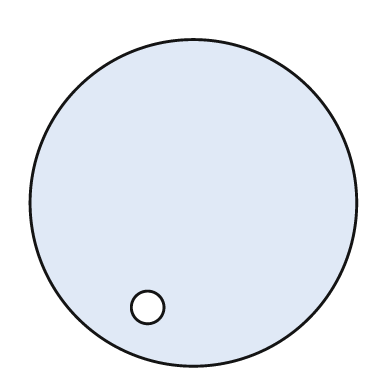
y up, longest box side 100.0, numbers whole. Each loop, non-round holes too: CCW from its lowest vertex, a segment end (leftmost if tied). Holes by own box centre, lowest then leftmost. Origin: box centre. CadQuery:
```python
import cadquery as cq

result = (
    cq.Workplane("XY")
    .moveTo(0.0, 0.0)
    .circle(50.0)
    .moveTo(-14.0, -32.0)
    .circle(5.0)
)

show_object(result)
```